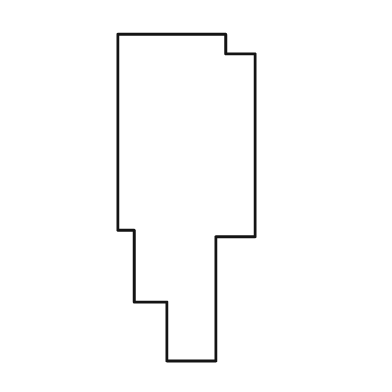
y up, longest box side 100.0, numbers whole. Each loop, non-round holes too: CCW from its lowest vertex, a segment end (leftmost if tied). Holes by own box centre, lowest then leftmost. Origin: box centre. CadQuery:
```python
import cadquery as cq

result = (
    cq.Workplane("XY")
    .moveTo(-6.0, -50.0)
    .lineTo(9.0, -50.0)
    .lineTo(9.0, -12.0)
    .lineTo(21.0, -12.0)
    .lineTo(21.0, 44.0)
    .lineTo(12.0, 44.0)
    .lineTo(12.0, 50.0)
    .lineTo(-21.0, 50.0)
    .lineTo(-21.0, -10.0)
    .lineTo(-16.0, -10.0)
    .lineTo(-16.0, -32.0)
    .lineTo(-6.0, -32.0)
    .close()
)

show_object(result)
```